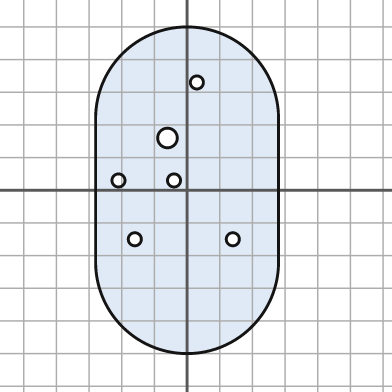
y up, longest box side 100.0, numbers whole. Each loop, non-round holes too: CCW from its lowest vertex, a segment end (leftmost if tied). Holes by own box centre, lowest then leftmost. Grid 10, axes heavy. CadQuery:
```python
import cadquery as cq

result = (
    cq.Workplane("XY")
    .moveTo(-28.0, -22.0)
    .threePointArc((0.0, -50.0), (28.0, -22.0))
    .lineTo(28.0, 22.0)
    .threePointArc((0.0, 50.0), (-28.0, 22.0))
    .close()
    .moveTo(-16.0, -15.0)
    .circle(2.0)
    .moveTo(14.0, -15.0)
    .circle(2.0)
    .moveTo(-21.0, 3.0)
    .circle(2.0)
    .moveTo(-4.0, 3.0)
    .circle(2.0)
    .moveTo(-6.0, 16.0)
    .circle(3.0)
    .moveTo(3.0, 33.0)
    .circle(2.0)
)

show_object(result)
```